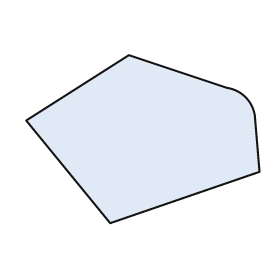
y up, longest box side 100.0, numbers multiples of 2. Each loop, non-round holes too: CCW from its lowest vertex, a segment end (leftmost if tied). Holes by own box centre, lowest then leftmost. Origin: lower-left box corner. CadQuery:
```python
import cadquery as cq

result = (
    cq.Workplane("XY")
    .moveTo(36.0, 0.0)
    .lineTo(100.0, 22.0)
    .lineTo(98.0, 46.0)
    .threePointArc((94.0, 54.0), (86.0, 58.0))
    .lineTo(44.0, 72.0)
    .lineTo(0.0, 44.0)
    .close()
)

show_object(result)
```